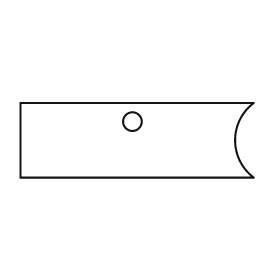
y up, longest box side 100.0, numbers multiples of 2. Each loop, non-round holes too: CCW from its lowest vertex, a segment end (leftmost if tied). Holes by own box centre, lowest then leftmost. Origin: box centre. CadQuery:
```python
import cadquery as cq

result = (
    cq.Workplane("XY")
    .moveTo(-50.0, -16.0)
    .lineTo(50.0, -16.0)
    .threePointArc((42.0, 0.0), (50.0, 16.0))
    .lineTo(-50.0, 16.0)
    .close()
    .moveTo(-2.0, 8.0)
    .circle(4.0)
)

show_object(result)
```